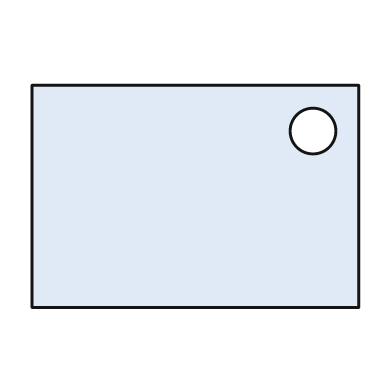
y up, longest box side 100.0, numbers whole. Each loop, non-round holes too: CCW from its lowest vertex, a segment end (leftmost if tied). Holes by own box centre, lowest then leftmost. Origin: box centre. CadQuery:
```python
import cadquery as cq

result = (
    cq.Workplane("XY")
    .moveTo(-50.0, -34.0)
    .lineTo(50.0, -34.0)
    .lineTo(50.0, 34.0)
    .lineTo(-50.0, 34.0)
    .close()
    .moveTo(36.0, 20.0)
    .circle(7.0)
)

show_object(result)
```